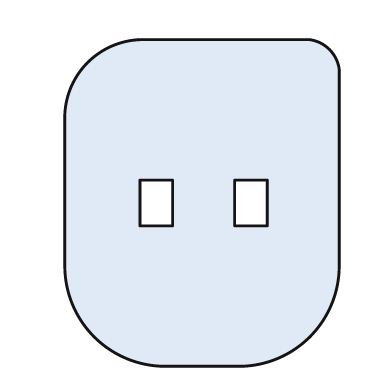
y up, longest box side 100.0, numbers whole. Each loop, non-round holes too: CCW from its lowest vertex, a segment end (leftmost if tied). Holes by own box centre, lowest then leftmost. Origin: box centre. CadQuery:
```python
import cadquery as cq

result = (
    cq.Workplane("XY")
    .moveTo(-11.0, -50.0)
    .lineTo(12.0, -50.0)
    .threePointArc((33.0, -41.0), (42.0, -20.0))
    .lineTo(42.0, 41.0)
    .threePointArc((39.0, 47.0), (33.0, 50.0))
    .lineTo(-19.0, 50.0)
    .threePointArc((-35.0, 43.0), (-42.0, 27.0))
    .lineTo(-42.0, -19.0)
    .threePointArc((-33.0, -41.0), (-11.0, -50.0))
    .close()
    .moveTo(-19.0, -7.0)
    .lineTo(-9.0, -7.0)
    .lineTo(-9.0, 7.0)
    .lineTo(-19.0, 7.0)
    .close()
    .moveTo(10.0, -7.0)
    .lineTo(20.0, -7.0)
    .lineTo(20.0, 7.0)
    .lineTo(10.0, 7.0)
    .close()
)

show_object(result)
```